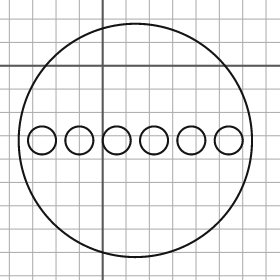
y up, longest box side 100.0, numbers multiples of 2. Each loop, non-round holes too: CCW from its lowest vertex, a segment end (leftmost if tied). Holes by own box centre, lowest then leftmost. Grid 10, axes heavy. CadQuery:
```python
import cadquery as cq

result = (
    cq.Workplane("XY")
    .moveTo(14.0, -32.0)
    .circle(50.0)
    .moveTo(-26.0, -32.0)
    .circle(6.0)
    .moveTo(-10.0, -32.0)
    .circle(6.0)
    .moveTo(6.0, -32.0)
    .circle(6.0)
    .moveTo(22.0, -32.0)
    .circle(6.0)
    .moveTo(38.0, -32.0)
    .circle(6.0)
    .moveTo(54.0, -32.0)
    .circle(6.0)
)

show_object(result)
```